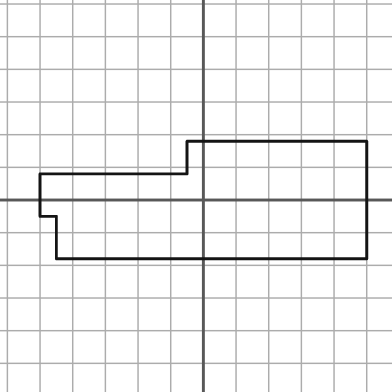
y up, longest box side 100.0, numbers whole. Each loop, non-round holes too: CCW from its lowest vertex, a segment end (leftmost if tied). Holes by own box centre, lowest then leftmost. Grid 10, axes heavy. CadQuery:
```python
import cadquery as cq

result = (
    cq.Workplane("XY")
    .moveTo(-45.0, -18.0)
    .lineTo(50.0, -18.0)
    .lineTo(50.0, 18.0)
    .lineTo(-5.0, 18.0)
    .lineTo(-5.0, 8.0)
    .lineTo(-50.0, 8.0)
    .lineTo(-50.0, -5.0)
    .lineTo(-45.0, -5.0)
    .close()
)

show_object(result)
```